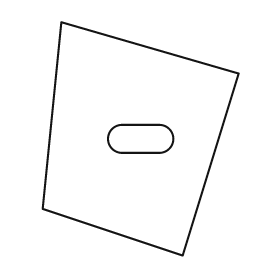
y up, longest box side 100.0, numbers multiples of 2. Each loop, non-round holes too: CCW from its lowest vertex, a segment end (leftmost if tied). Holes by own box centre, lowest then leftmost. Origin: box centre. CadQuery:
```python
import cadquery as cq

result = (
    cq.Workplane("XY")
    .moveTo(18.0, -50.0)
    .lineTo(42.0, 28.0)
    .lineTo(-34.0, 50.0)
    .lineTo(-42.0, -30.0)
    .close()
    .moveTo(-8.0, -6.0)
    .lineTo(8.0, -6.0)
    .threePointArc((14.0, 0.0), (8.0, 6.0))
    .lineTo(-8.0, 6.0)
    .threePointArc((-14.0, 0.0), (-8.0, -6.0))
    .close()
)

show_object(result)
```